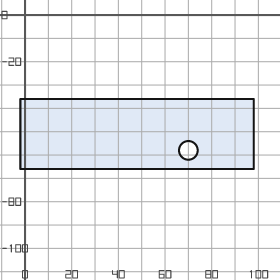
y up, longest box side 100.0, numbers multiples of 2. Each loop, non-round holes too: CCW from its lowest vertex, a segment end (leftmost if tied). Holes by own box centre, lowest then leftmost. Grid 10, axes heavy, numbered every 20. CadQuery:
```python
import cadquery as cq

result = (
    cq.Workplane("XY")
    .moveTo(-2.0, -66.0)
    .lineTo(98.0, -66.0)
    .lineTo(98.0, -36.0)
    .lineTo(-2.0, -36.0)
    .close()
    .moveTo(70.0, -58.0)
    .circle(4.0)
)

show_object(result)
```